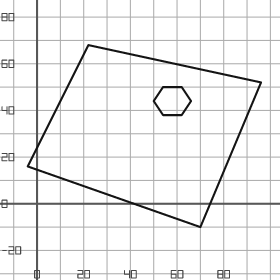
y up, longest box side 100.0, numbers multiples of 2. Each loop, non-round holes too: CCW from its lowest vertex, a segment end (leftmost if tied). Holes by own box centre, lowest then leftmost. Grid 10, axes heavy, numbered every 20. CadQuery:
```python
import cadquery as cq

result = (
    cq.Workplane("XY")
    .moveTo(70.0, -10.0)
    .lineTo(96.0, 52.0)
    .lineTo(22.0, 68.0)
    .lineTo(-4.0, 16.0)
    .close()
    .moveTo(54.0, 38.0)
    .lineTo(62.0, 38.0)
    .lineTo(66.0, 44.0)
    .lineTo(62.0, 50.0)
    .lineTo(54.0, 50.0)
    .lineTo(50.0, 44.0)
    .close()
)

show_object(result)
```